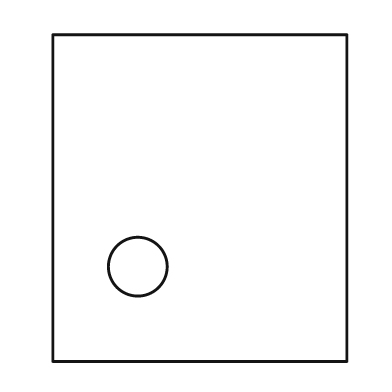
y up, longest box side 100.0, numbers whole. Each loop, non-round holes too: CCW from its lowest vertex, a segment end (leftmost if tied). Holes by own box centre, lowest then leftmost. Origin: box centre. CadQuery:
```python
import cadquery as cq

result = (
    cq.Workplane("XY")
    .moveTo(-45.0, -50.0)
    .lineTo(45.0, -50.0)
    .lineTo(45.0, 50.0)
    .lineTo(-45.0, 50.0)
    .close()
    .moveTo(-19.0, -21.0)
    .circle(9.0)
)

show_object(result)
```